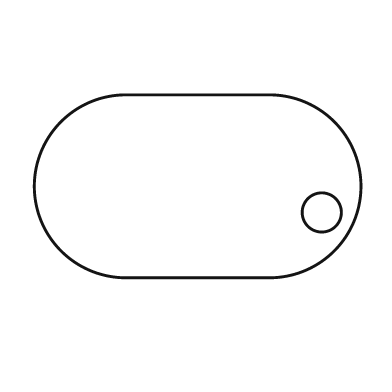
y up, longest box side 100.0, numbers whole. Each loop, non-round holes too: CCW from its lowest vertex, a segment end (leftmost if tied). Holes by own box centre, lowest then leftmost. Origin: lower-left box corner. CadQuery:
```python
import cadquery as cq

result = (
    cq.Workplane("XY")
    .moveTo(28.0, 0.0)
    .lineTo(72.0, 0.0)
    .threePointArc((100.0, 28.0), (72.0, 56.0))
    .lineTo(28.0, 56.0)
    .threePointArc((0.0, 28.0), (28.0, 0.0))
    .close()
    .moveTo(88.0, 20.0)
    .circle(6.0)
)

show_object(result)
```